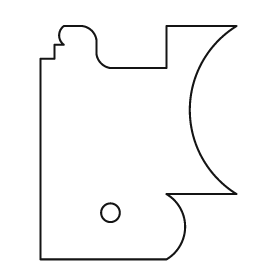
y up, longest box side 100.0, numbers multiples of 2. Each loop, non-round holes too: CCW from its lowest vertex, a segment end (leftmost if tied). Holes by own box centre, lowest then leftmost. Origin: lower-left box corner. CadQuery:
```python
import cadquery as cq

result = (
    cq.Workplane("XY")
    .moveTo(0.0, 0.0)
    .lineTo(54.0, 0.0)
    .threePointArc((62.0, 14.0), (54.0, 28.0))
    .lineTo(84.0, 28.0)
    .threePointArc((64.0, 64.0), (84.0, 100.0))
    .lineTo(54.0, 100.0)
    .lineTo(54.0, 82.0)
    .lineTo(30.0, 82.0)
    .threePointArc((26.0, 84.0), (24.0, 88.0))
    .lineTo(24.0, 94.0)
    .threePointArc((22.0, 98.0), (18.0, 100.0))
    .lineTo(10.0, 100.0)
    .threePointArc((8.0, 96.0), (10.0, 92.0))
    .lineTo(6.0, 92.0)
    .lineTo(6.0, 86.0)
    .lineTo(0.0, 86.0)
    .close()
    .moveTo(30.0, 20.0)
    .circle(4.0)
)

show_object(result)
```